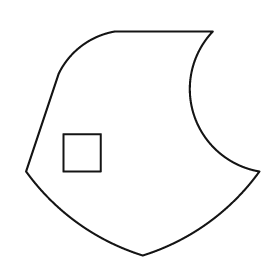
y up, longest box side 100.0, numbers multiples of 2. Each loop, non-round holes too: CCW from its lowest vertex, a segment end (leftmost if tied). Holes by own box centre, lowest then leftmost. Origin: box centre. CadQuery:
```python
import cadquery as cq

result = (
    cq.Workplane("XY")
    .moveTo(0.0, -48.0)
    .threePointArc((28.0, -34.0), (50.0, -12.0))
    .threePointArc((22.0, 12.0), (30.0, 48.0))
    .lineTo(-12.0, 48.0)
    .threePointArc((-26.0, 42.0), (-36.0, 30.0))
    .lineTo(-50.0, -12.0)
    .threePointArc((-28.0, -34.0), (0.0, -48.0))
    .close()
    .moveTo(-34.0, -12.0)
    .lineTo(-18.0, -12.0)
    .lineTo(-18.0, 4.0)
    .lineTo(-34.0, 4.0)
    .close()
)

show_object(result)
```